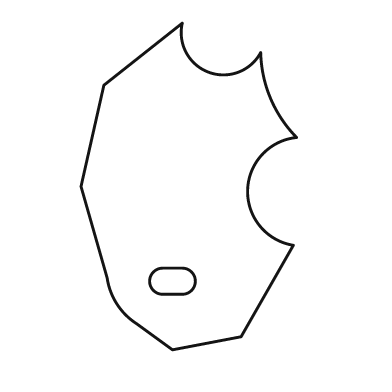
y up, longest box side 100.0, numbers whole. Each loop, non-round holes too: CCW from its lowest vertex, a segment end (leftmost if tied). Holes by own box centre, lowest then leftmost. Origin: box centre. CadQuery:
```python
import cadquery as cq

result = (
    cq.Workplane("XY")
    .moveTo(-5.0, -50.0)
    .lineTo(16.0, -46.0)
    .lineTo(32.0, -18.0)
    .threePointArc((18.0, -1.0), (33.0, 15.0))
    .threePointArc((25.0, 27.0), (22.0, 41.0))
    .threePointArc((6.0, 35.0), (-2.0, 50.0))
    .lineTo(-26.0, 31.0)
    .lineTo(-33.0, 0.0)
    .lineTo(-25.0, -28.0)
    .threePointArc((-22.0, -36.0), (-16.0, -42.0))
    .close()
    .moveTo(-8.0, -33.0)
    .lineTo(-2.0, -33.0)
    .threePointArc((2.0, -29.0), (-2.0, -25.0))
    .lineTo(-8.0, -25.0)
    .threePointArc((-12.0, -29.0), (-8.0, -33.0))
    .close()
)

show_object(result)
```